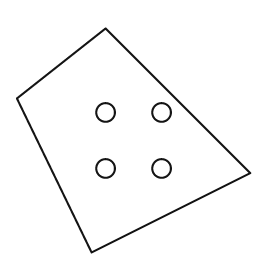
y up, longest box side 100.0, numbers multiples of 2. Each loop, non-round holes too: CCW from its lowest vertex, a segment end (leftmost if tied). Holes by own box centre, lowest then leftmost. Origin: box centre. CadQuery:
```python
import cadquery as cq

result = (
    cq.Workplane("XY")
    .moveTo(-18.0, -48.0)
    .lineTo(50.0, -14.0)
    .lineTo(-12.0, 48.0)
    .lineTo(-50.0, 18.0)
    .close()
    .moveTo(-12.0, -12.0)
    .circle(4.0)
    .moveTo(12.0, -12.0)
    .circle(4.0)
    .moveTo(-12.0, 12.0)
    .circle(4.0)
    .moveTo(12.0, 12.0)
    .circle(4.0)
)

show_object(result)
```